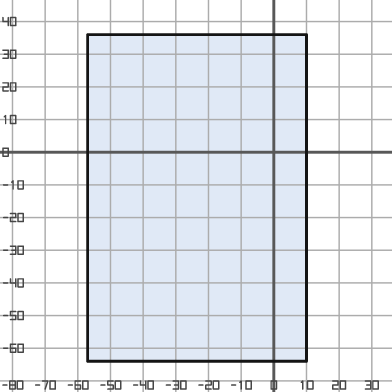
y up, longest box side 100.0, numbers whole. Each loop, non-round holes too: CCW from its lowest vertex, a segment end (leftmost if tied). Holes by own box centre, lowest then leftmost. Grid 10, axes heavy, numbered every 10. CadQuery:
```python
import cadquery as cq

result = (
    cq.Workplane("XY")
    .moveTo(-57.0, -64.0)
    .lineTo(10.0, -64.0)
    .lineTo(10.0, 36.0)
    .lineTo(-57.0, 36.0)
    .close()
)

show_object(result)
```